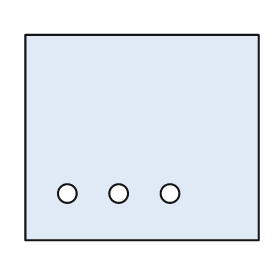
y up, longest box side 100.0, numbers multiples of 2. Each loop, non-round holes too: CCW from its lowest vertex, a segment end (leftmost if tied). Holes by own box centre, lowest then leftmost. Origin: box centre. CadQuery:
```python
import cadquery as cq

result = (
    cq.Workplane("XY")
    .moveTo(-50.0, -44.0)
    .lineTo(50.0, -44.0)
    .lineTo(50.0, 44.0)
    .lineTo(-50.0, 44.0)
    .close()
    .moveTo(-32.0, -24.0)
    .circle(4.0)
    .moveTo(-10.0, -24.0)
    .circle(4.0)
    .moveTo(12.0, -24.0)
    .circle(4.0)
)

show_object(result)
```